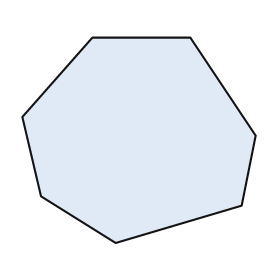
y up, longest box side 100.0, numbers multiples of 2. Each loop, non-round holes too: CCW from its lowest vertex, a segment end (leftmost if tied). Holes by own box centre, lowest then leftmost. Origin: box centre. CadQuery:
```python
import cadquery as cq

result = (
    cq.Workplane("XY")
    .moveTo(-10.0, -44.0)
    .lineTo(44.0, -28.0)
    .lineTo(50.0, 2.0)
    .lineTo(22.0, 44.0)
    .lineTo(-20.0, 44.0)
    .lineTo(-50.0, 10.0)
    .lineTo(-42.0, -24.0)
    .close()
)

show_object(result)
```